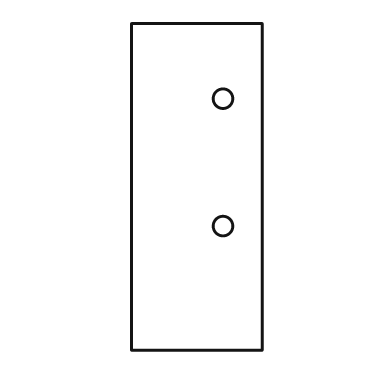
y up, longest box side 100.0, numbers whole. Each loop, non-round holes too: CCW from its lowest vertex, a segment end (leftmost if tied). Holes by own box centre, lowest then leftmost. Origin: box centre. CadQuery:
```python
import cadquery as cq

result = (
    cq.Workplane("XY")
    .moveTo(-20.0, -50.0)
    .lineTo(20.0, -50.0)
    .lineTo(20.0, 50.0)
    .lineTo(-20.0, 50.0)
    .close()
    .moveTo(8.0, -12.0)
    .circle(3.0)
    .moveTo(8.0, 27.0)
    .circle(3.0)
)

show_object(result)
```